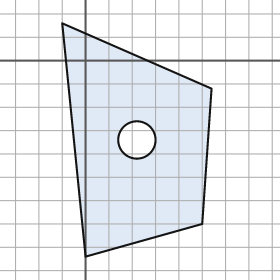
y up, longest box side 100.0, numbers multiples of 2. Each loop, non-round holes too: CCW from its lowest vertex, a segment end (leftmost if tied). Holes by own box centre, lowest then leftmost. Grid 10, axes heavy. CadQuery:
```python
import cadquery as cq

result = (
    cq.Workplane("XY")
    .moveTo(0.0, -84.0)
    .lineTo(50.0, -70.0)
    .lineTo(54.0, -12.0)
    .lineTo(-10.0, 16.0)
    .close()
    .moveTo(22.0, -34.0)
    .circle(8.0)
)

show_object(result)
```